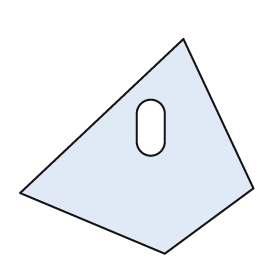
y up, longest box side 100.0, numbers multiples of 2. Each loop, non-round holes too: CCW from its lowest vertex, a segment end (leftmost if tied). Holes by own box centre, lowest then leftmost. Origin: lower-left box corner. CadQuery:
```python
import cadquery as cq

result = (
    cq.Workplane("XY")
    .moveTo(62.0, 0.0)
    .lineTo(100.0, 28.0)
    .lineTo(70.0, 92.0)
    .lineTo(0.0, 26.0)
    .close()
    .moveTo(50.0, 48.0)
    .threePointArc((56.0, 42.0), (62.0, 48.0))
    .lineTo(62.0, 60.0)
    .threePointArc((56.0, 66.0), (50.0, 60.0))
    .close()
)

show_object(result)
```